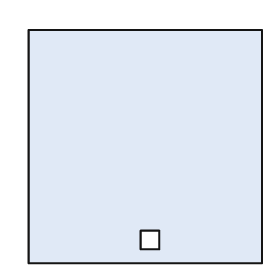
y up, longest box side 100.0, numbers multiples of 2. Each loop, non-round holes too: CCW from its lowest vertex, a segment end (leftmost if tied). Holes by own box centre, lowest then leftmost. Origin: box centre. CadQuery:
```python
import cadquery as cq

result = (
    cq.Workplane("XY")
    .moveTo(-50.0, -50.0)
    .lineTo(50.0, -50.0)
    .lineTo(50.0, 50.0)
    .lineTo(-50.0, 50.0)
    .close()
    .moveTo(-2.0, -44.0)
    .lineTo(6.0, -44.0)
    .lineTo(6.0, -36.0)
    .lineTo(-2.0, -36.0)
    .close()
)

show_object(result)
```